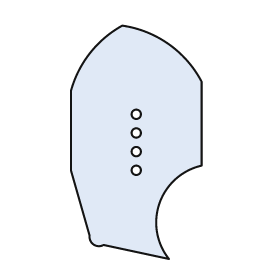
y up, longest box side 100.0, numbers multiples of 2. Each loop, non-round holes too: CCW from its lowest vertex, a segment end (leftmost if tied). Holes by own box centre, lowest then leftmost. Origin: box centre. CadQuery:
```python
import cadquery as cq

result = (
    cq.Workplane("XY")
    .moveTo(14.0, -50.0)
    .threePointArc((10.0, -26.0), (28.0, -10.0))
    .lineTo(28.0, 26.0)
    .threePointArc((14.0, 42.0), (-6.0, 50.0))
    .threePointArc((-20.0, 38.0), (-28.0, 22.0))
    .lineTo(-28.0, -12.0)
    .lineTo(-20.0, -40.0)
    .threePointArc((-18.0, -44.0), (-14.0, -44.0))
    .close()
    .moveTo(0.0, -12.0)
    .circle(2.0)
    .moveTo(0.0, -4.0)
    .circle(2.0)
    .moveTo(0.0, 4.0)
    .circle(2.0)
    .moveTo(0.0, 12.0)
    .circle(2.0)
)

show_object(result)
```